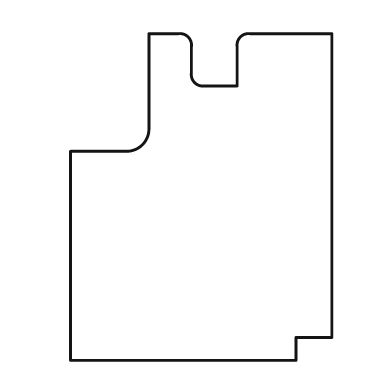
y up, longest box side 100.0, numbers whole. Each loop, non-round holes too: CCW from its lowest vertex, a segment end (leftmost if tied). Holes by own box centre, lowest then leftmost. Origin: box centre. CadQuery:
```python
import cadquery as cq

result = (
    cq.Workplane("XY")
    .moveTo(-40.0, -50.0)
    .lineTo(29.0, -50.0)
    .lineTo(29.0, -43.0)
    .lineTo(40.0, -43.0)
    .lineTo(40.0, 50.0)
    .lineTo(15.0, 50.0)
    .threePointArc((12.0, 49.0), (11.0, 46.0))
    .lineTo(11.0, 34.0)
    .lineTo(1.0, 34.0)
    .threePointArc((-2.0, 35.0), (-3.0, 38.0))
    .lineTo(-3.0, 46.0)
    .threePointArc((-4.0, 49.0), (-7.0, 50.0))
    .lineTo(-16.0, 50.0)
    .lineTo(-16.0, 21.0)
    .threePointArc((-18.0, 16.0), (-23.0, 14.0))
    .lineTo(-40.0, 14.0)
    .close()
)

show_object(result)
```